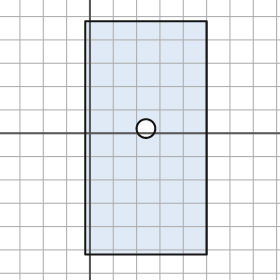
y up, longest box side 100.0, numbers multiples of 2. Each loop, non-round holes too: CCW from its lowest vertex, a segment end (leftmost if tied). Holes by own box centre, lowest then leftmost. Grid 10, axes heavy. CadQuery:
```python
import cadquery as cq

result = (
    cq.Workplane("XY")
    .moveTo(-2.0, -52.0)
    .lineTo(50.0, -52.0)
    .lineTo(50.0, 48.0)
    .lineTo(-2.0, 48.0)
    .close()
    .moveTo(24.0, 2.0)
    .circle(4.0)
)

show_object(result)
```